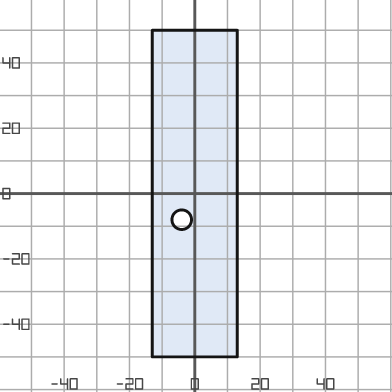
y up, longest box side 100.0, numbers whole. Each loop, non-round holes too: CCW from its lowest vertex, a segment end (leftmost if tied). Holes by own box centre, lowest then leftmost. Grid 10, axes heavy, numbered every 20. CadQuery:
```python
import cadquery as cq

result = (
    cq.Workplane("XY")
    .moveTo(-13.0, -50.0)
    .lineTo(13.0, -50.0)
    .lineTo(13.0, 50.0)
    .lineTo(-13.0, 50.0)
    .close()
    .moveTo(-4.0, -8.0)
    .circle(3.0)
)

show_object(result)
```